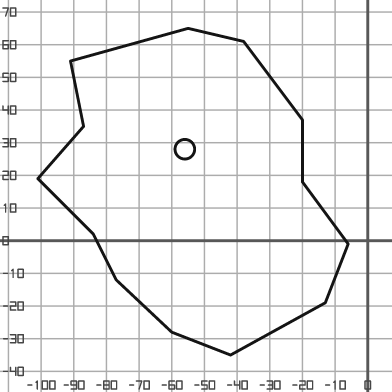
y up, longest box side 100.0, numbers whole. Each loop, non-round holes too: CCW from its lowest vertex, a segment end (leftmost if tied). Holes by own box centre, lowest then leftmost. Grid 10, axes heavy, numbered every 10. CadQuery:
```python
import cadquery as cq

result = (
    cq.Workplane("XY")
    .moveTo(-42.0, -35.0)
    .lineTo(-13.0, -19.0)
    .lineTo(-6.0, -1.0)
    .lineTo(-20.0, 18.0)
    .lineTo(-20.0, 37.0)
    .lineTo(-38.0, 61.0)
    .lineTo(-55.0, 65.0)
    .lineTo(-91.0, 55.0)
    .lineTo(-87.0, 35.0)
    .lineTo(-101.0, 19.0)
    .lineTo(-84.0, 2.0)
    .lineTo(-77.0, -12.0)
    .lineTo(-60.0, -28.0)
    .close()
    .moveTo(-56.0, 28.0)
    .circle(3.0)
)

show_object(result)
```